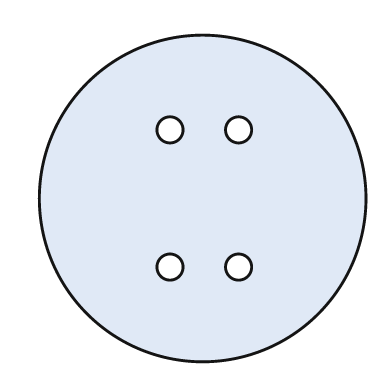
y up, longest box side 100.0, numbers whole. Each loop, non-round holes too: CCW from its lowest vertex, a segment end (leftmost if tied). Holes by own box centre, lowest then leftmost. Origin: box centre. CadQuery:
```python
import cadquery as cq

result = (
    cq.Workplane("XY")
    .moveTo(0.0, 0.0)
    .circle(50.0)
    .moveTo(-10.0, -21.0)
    .circle(4.0)
    .moveTo(11.0, -21.0)
    .circle(4.0)
    .moveTo(-10.0, 21.0)
    .circle(4.0)
    .moveTo(11.0, 21.0)
    .circle(4.0)
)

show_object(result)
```